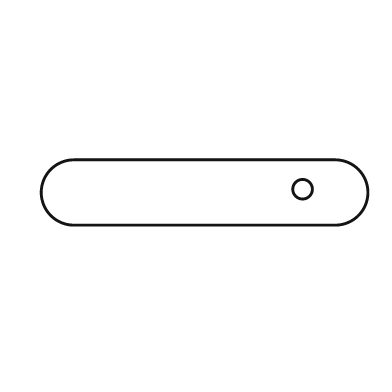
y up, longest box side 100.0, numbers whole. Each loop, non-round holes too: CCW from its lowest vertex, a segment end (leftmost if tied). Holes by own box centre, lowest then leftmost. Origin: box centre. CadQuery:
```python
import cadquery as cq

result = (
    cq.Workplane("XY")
    .moveTo(-40.0, -10.0)
    .lineTo(40.0, -10.0)
    .threePointArc((50.0, 0.0), (40.0, 10.0))
    .lineTo(-40.0, 10.0)
    .threePointArc((-50.0, 0.0), (-40.0, -10.0))
    .close()
    .moveTo(30.0, 1.0)
    .circle(3.0)
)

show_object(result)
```